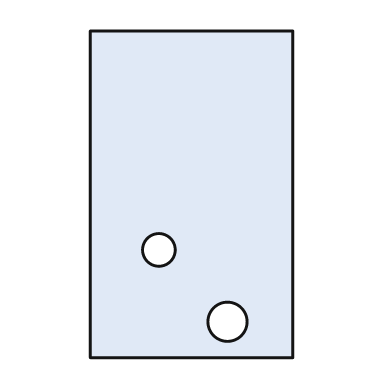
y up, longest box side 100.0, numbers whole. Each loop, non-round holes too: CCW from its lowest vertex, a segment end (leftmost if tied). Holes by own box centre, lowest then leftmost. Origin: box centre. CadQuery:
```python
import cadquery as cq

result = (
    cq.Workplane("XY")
    .moveTo(-31.0, -50.0)
    .lineTo(31.0, -50.0)
    .lineTo(31.0, 50.0)
    .lineTo(-31.0, 50.0)
    .close()
    .moveTo(11.0, -39.0)
    .circle(6.0)
    .moveTo(-10.0, -17.0)
    .circle(5.0)
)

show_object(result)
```